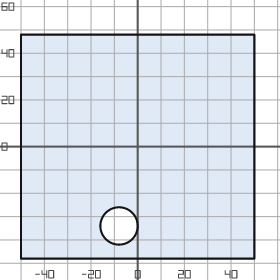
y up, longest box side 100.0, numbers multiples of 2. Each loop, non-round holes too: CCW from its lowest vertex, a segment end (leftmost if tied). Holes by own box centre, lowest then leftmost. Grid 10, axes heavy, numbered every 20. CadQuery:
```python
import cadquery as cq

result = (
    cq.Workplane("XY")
    .moveTo(-50.0, -48.0)
    .lineTo(50.0, -48.0)
    .lineTo(50.0, 48.0)
    .lineTo(-50.0, 48.0)
    .close()
    .moveTo(-8.0, -34.0)
    .circle(8.0)
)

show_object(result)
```